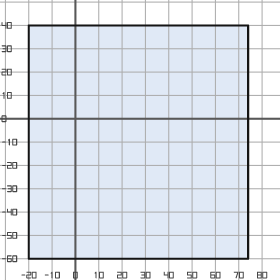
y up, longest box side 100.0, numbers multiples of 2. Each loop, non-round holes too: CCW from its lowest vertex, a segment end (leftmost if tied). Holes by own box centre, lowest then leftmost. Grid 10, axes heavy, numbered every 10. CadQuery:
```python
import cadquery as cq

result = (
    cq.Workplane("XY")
    .moveTo(-20.0, -60.0)
    .lineTo(74.0, -60.0)
    .lineTo(74.0, 40.0)
    .lineTo(-20.0, 40.0)
    .close()
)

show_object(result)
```